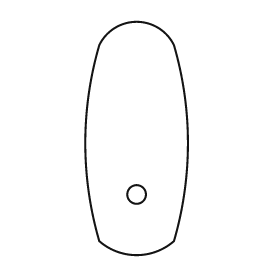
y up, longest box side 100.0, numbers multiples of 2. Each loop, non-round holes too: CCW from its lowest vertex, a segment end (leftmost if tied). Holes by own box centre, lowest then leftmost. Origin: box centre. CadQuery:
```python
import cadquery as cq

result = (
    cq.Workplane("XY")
    .moveTo(-16.0, -44.0)
    .threePointArc((0.0, -50.0), (16.0, -44.0))
    .threePointArc((22.0, -2.0), (16.0, 40.0))
    .threePointArc((0.0, 50.0), (-16.0, 40.0))
    .threePointArc((-22.0, -2.0), (-16.0, -44.0))
    .close()
    .moveTo(0.0, -24.0)
    .circle(4.0)
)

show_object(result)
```